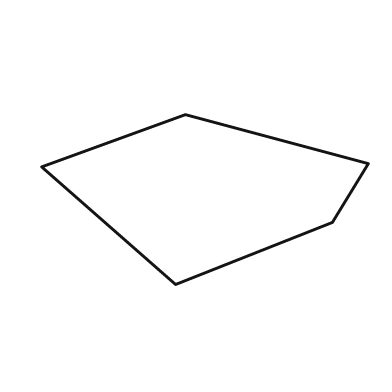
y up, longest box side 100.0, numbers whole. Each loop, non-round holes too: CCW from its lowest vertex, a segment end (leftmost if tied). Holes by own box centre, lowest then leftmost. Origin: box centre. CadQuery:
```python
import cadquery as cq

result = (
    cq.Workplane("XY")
    .moveTo(-9.0, -26.0)
    .lineTo(39.0, -7.0)
    .lineTo(50.0, 11.0)
    .lineTo(-6.0, 26.0)
    .lineTo(-50.0, 10.0)
    .close()
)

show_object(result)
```